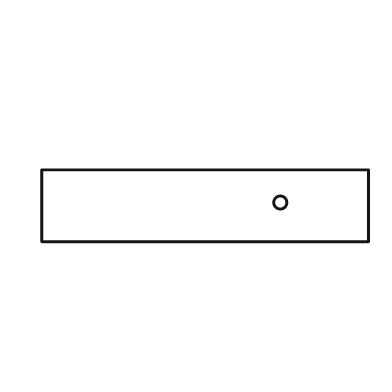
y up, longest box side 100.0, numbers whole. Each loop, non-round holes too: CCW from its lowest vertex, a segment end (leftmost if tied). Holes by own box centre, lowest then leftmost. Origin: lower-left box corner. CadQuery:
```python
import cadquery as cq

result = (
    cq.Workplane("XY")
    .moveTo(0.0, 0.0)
    .lineTo(100.0, 0.0)
    .lineTo(100.0, 22.0)
    .lineTo(0.0, 22.0)
    .close()
    .moveTo(73.0, 12.0)
    .circle(2.0)
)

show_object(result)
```